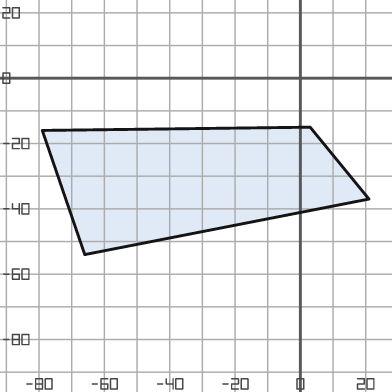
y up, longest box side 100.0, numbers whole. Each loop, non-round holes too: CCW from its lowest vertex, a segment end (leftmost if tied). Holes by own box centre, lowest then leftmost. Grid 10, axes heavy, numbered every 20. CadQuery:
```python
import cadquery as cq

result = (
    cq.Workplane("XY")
    .moveTo(-66.0, -54.0)
    .lineTo(21.0, -37.0)
    .lineTo(3.0, -15.0)
    .lineTo(-79.0, -16.0)
    .close()
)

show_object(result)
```